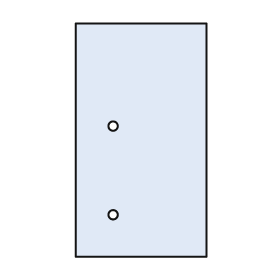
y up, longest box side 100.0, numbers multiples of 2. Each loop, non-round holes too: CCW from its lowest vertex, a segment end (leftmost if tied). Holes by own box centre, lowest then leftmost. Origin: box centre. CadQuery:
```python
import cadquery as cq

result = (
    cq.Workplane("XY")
    .moveTo(-28.0, -50.0)
    .lineTo(28.0, -50.0)
    .lineTo(28.0, 50.0)
    .lineTo(-28.0, 50.0)
    .close()
    .moveTo(-12.0, -32.0)
    .circle(2.0)
    .moveTo(-12.0, 6.0)
    .circle(2.0)
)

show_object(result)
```